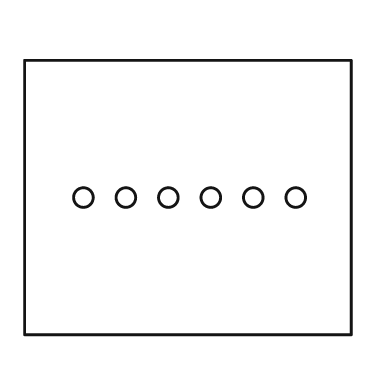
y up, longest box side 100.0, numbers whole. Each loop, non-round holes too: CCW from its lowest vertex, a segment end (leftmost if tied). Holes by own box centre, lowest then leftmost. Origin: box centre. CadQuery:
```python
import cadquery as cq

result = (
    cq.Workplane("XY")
    .moveTo(-50.0, -42.0)
    .lineTo(50.0, -42.0)
    .lineTo(50.0, 42.0)
    .lineTo(-50.0, 42.0)
    .close()
    .moveTo(-32.0, 0.0)
    .circle(3.0)
    .moveTo(-19.0, 0.0)
    .circle(3.0)
    .moveTo(-6.0, 0.0)
    .circle(3.0)
    .moveTo(7.0, 0.0)
    .circle(3.0)
    .moveTo(20.0, 0.0)
    .circle(3.0)
    .moveTo(33.0, 0.0)
    .circle(3.0)
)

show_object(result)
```